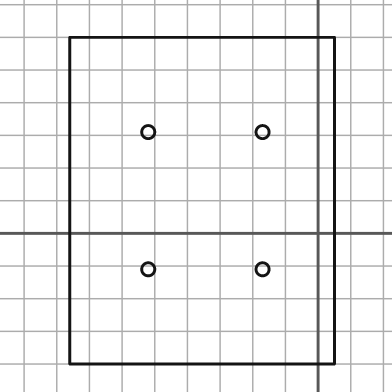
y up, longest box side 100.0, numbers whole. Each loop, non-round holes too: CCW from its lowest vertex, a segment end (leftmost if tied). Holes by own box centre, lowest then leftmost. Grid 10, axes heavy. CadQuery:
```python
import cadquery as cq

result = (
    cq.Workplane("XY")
    .moveTo(-76.0, -40.0)
    .lineTo(5.0, -40.0)
    .lineTo(5.0, 60.0)
    .lineTo(-76.0, 60.0)
    .close()
    .moveTo(-52.0, -11.0)
    .circle(2.0)
    .moveTo(-17.0, -11.0)
    .circle(2.0)
    .moveTo(-52.0, 31.0)
    .circle(2.0)
    .moveTo(-17.0, 31.0)
    .circle(2.0)
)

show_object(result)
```